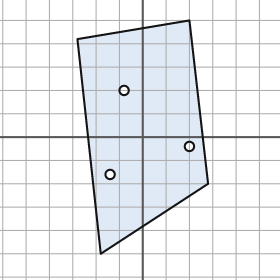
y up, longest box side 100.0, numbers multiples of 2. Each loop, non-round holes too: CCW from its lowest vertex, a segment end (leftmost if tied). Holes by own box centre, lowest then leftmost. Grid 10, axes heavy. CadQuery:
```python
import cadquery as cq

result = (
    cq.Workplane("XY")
    .moveTo(-18.0, -50.0)
    .lineTo(28.0, -20.0)
    .lineTo(20.0, 50.0)
    .lineTo(-28.0, 42.0)
    .close()
    .moveTo(-14.0, -16.0)
    .circle(2.0)
    .moveTo(20.0, -4.0)
    .circle(2.0)
    .moveTo(-8.0, 20.0)
    .circle(2.0)
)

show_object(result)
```